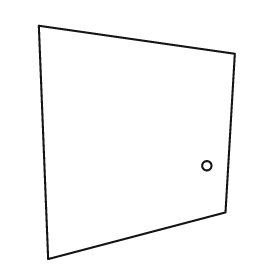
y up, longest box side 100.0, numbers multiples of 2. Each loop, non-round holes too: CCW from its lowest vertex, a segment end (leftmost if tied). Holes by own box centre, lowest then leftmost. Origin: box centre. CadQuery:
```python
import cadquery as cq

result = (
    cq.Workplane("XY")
    .moveTo(-38.0, -50.0)
    .lineTo(38.0, -30.0)
    .lineTo(42.0, 38.0)
    .lineTo(-42.0, 50.0)
    .close()
    .moveTo(30.0, -10.0)
    .circle(2.0)
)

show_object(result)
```